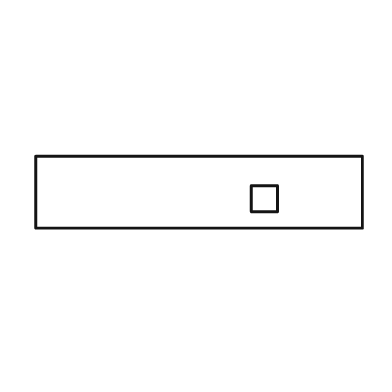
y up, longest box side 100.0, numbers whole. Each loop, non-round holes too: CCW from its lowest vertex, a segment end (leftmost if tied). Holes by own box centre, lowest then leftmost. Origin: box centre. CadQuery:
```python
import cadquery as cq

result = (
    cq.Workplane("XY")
    .moveTo(-50.0, -11.0)
    .lineTo(50.0, -11.0)
    .lineTo(50.0, 11.0)
    .lineTo(-50.0, 11.0)
    .close()
    .moveTo(16.0, -6.0)
    .lineTo(24.0, -6.0)
    .lineTo(24.0, 2.0)
    .lineTo(16.0, 2.0)
    .close()
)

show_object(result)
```